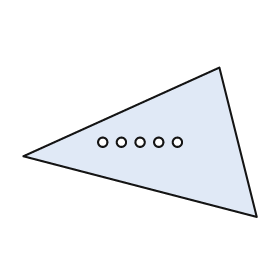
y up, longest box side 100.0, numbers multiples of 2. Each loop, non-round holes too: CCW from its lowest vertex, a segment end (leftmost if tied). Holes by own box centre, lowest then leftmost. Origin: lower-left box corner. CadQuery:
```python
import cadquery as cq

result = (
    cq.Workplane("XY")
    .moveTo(100.0, 0.0)
    .lineTo(84.0, 64.0)
    .lineTo(0.0, 26.0)
    .close()
    .moveTo(34.0, 32.0)
    .circle(2.0)
    .moveTo(42.0, 32.0)
    .circle(2.0)
    .moveTo(50.0, 32.0)
    .circle(2.0)
    .moveTo(58.0, 32.0)
    .circle(2.0)
    .moveTo(66.0, 32.0)
    .circle(2.0)
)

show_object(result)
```